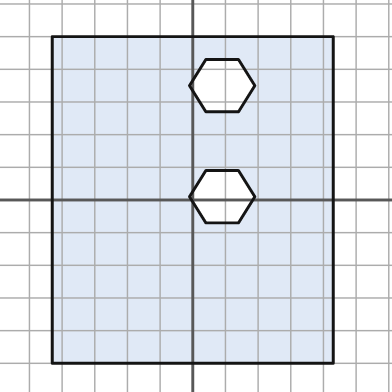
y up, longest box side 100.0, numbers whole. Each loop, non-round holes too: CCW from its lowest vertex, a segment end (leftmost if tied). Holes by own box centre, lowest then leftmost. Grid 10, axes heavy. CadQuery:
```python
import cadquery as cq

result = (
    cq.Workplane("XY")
    .moveTo(-43.0, -50.0)
    .lineTo(43.0, -50.0)
    .lineTo(43.0, 50.0)
    .lineTo(-43.0, 50.0)
    .close()
    .moveTo(4.0, -7.0)
    .lineTo(14.0, -7.0)
    .lineTo(19.0, 1.0)
    .lineTo(14.0, 9.0)
    .lineTo(4.0, 9.0)
    .lineTo(-1.0, 1.0)
    .close()
    .moveTo(4.0, 27.0)
    .lineTo(14.0, 27.0)
    .lineTo(19.0, 35.0)
    .lineTo(14.0, 43.0)
    .lineTo(4.0, 43.0)
    .lineTo(-1.0, 35.0)
    .close()
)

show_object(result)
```